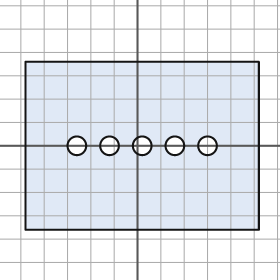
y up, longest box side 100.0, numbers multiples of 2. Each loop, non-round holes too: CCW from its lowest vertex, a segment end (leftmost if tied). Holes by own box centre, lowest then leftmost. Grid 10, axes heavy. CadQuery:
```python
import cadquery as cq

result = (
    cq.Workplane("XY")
    .moveTo(-48.0, -36.0)
    .lineTo(52.0, -36.0)
    .lineTo(52.0, 36.0)
    .lineTo(-48.0, 36.0)
    .close()
    .moveTo(-26.0, 0.0)
    .circle(4.0)
    .moveTo(-12.0, 0.0)
    .circle(4.0)
    .moveTo(2.0, 0.0)
    .circle(4.0)
    .moveTo(16.0, 0.0)
    .circle(4.0)
    .moveTo(30.0, 0.0)
    .circle(4.0)
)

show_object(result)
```